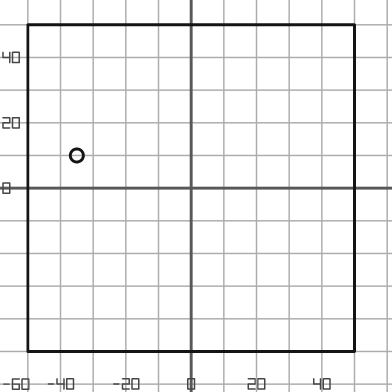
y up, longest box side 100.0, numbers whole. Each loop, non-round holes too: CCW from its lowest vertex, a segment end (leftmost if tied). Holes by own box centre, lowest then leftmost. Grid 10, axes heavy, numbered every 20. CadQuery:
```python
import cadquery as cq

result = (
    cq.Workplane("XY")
    .moveTo(-50.0, -50.0)
    .lineTo(50.0, -50.0)
    .lineTo(50.0, 50.0)
    .lineTo(-50.0, 50.0)
    .close()
    .moveTo(-35.0, 10.0)
    .circle(2.0)
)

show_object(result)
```